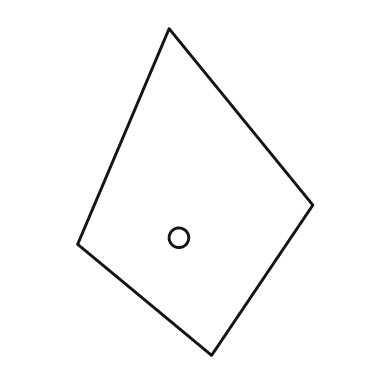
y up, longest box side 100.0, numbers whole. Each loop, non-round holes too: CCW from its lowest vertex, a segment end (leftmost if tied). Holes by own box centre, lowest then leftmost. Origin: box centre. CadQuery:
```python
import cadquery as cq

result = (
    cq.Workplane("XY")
    .moveTo(5.0, -50.0)
    .lineTo(36.0, -4.0)
    .lineTo(-8.0, 50.0)
    .lineTo(-36.0, -16.0)
    .close()
    .moveTo(-5.0, -14.0)
    .circle(3.0)
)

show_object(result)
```